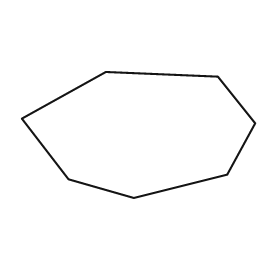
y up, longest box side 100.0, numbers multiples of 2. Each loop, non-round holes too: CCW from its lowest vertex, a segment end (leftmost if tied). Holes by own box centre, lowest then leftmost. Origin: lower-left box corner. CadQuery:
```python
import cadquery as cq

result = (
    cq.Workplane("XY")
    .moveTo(48.0, 0.0)
    .lineTo(88.0, 10.0)
    .lineTo(100.0, 32.0)
    .lineTo(84.0, 52.0)
    .lineTo(36.0, 54.0)
    .lineTo(0.0, 34.0)
    .lineTo(20.0, 8.0)
    .close()
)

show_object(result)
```